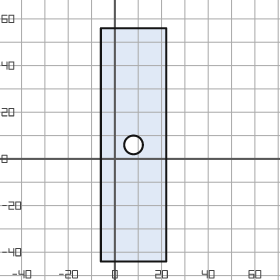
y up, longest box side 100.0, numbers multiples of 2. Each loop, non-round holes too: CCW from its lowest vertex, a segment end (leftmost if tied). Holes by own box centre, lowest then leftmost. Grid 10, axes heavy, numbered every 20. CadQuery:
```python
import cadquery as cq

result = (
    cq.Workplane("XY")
    .moveTo(-6.0, -44.0)
    .lineTo(22.0, -44.0)
    .lineTo(22.0, 56.0)
    .lineTo(-6.0, 56.0)
    .close()
    .moveTo(8.0, 6.0)
    .circle(4.0)
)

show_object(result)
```